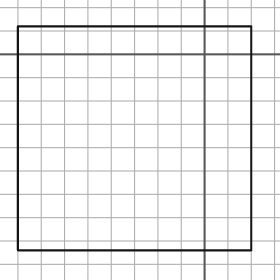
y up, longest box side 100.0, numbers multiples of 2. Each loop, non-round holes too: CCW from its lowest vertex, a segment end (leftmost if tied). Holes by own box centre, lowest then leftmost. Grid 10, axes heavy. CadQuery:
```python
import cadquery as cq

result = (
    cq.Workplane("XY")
    .moveTo(-80.0, -84.0)
    .lineTo(20.0, -84.0)
    .lineTo(20.0, 12.0)
    .lineTo(-80.0, 12.0)
    .close()
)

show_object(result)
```